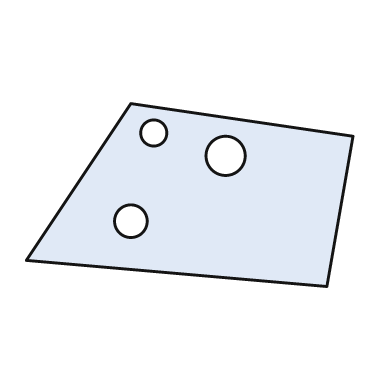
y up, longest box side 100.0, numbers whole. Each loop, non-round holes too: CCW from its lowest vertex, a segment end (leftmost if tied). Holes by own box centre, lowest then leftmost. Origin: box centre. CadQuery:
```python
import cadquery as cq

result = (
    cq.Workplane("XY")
    .moveTo(42.0, -28.0)
    .lineTo(50.0, 18.0)
    .lineTo(-18.0, 28.0)
    .lineTo(-50.0, -20.0)
    .close()
    .moveTo(-18.0, -8.0)
    .circle(5.0)
    .moveTo(11.0, 12.0)
    .circle(6.0)
    .moveTo(-11.0, 19.0)
    .circle(4.0)
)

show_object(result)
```